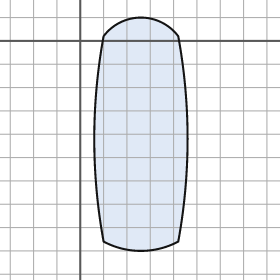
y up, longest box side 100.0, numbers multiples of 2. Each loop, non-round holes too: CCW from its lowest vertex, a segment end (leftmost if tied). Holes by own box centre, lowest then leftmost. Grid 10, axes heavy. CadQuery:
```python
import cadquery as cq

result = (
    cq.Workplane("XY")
    .moveTo(10.0, -86.0)
    .threePointArc((26.0, -90.0), (42.0, -86.0))
    .threePointArc((46.0, -42.0), (42.0, 2.0))
    .threePointArc((26.0, 10.0), (10.0, 2.0))
    .threePointArc((6.0, -42.0), (10.0, -86.0))
    .close()
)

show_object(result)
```